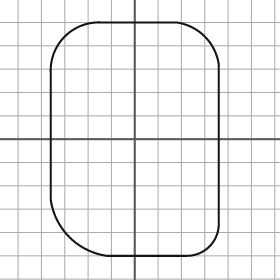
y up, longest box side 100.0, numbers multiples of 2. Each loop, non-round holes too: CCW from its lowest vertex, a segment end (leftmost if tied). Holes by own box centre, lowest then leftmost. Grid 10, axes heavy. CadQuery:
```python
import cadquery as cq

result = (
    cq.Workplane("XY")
    .moveTo(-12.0, -50.0)
    .lineTo(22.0, -50.0)
    .threePointArc((32.0, -46.0), (36.0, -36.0))
    .lineTo(36.0, 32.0)
    .threePointArc((30.0, 44.0), (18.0, 50.0))
    .lineTo(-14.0, 50.0)
    .threePointArc((-30.0, 44.0), (-36.0, 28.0))
    .lineTo(-36.0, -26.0)
    .threePointArc((-28.0, -42.0), (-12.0, -50.0))
    .close()
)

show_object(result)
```